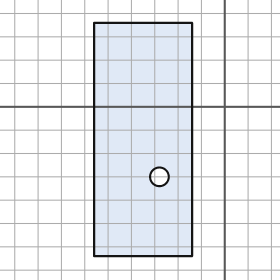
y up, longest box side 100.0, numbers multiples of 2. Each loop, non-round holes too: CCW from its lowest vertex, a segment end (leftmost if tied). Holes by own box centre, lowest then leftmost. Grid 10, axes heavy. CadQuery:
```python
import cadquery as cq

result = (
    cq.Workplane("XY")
    .moveTo(-56.0, -64.0)
    .lineTo(-14.0, -64.0)
    .lineTo(-14.0, 36.0)
    .lineTo(-56.0, 36.0)
    .close()
    .moveTo(-28.0, -30.0)
    .circle(4.0)
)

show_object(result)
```